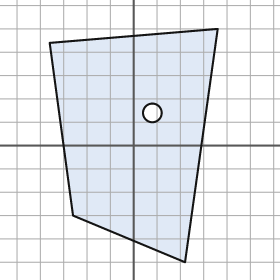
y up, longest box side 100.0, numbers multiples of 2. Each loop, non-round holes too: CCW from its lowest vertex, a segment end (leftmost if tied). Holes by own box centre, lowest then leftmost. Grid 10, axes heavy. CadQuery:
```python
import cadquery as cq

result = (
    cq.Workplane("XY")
    .moveTo(22.0, -50.0)
    .lineTo(36.0, 50.0)
    .lineTo(-36.0, 44.0)
    .lineTo(-26.0, -30.0)
    .close()
    .moveTo(8.0, 14.0)
    .circle(4.0)
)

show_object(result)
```